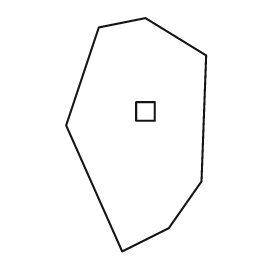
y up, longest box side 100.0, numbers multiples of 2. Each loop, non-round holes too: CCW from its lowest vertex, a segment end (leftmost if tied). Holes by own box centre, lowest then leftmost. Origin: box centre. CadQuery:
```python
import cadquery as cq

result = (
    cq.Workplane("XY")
    .moveTo(-6.0, -50.0)
    .lineTo(14.0, -40.0)
    .lineTo(28.0, -20.0)
    .lineTo(30.0, 34.0)
    .lineTo(4.0, 50.0)
    .lineTo(-16.0, 46.0)
    .lineTo(-30.0, 4.0)
    .close()
    .moveTo(0.0, 6.0)
    .lineTo(8.0, 6.0)
    .lineTo(8.0, 14.0)
    .lineTo(0.0, 14.0)
    .close()
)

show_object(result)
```